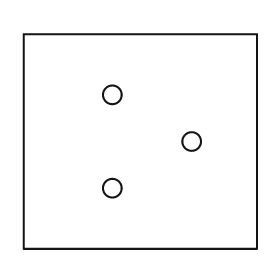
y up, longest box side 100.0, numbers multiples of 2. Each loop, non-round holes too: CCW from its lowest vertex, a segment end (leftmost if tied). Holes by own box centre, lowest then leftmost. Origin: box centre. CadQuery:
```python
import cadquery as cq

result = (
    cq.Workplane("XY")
    .moveTo(-50.0, -46.0)
    .lineTo(50.0, -46.0)
    .lineTo(50.0, 46.0)
    .lineTo(-50.0, 46.0)
    .close()
    .moveTo(-12.0, -20.0)
    .circle(4.0)
    .moveTo(22.0, 0.0)
    .circle(4.0)
    .moveTo(-12.0, 20.0)
    .circle(4.0)
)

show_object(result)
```